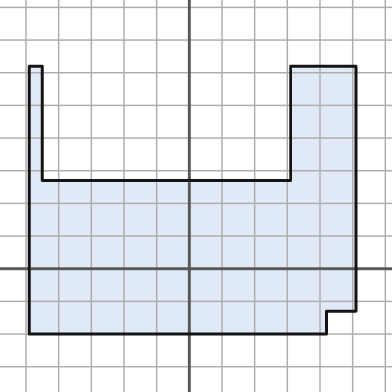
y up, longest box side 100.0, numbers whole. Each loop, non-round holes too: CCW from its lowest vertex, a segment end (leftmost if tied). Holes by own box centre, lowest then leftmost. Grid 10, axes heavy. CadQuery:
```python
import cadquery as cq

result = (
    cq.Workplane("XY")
    .moveTo(-49.0, -20.0)
    .lineTo(42.0, -20.0)
    .lineTo(42.0, -13.0)
    .lineTo(51.0, -13.0)
    .lineTo(51.0, 62.0)
    .lineTo(31.0, 62.0)
    .lineTo(31.0, 27.0)
    .lineTo(-45.0, 27.0)
    .lineTo(-45.0, 62.0)
    .lineTo(-49.0, 62.0)
    .close()
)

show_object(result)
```